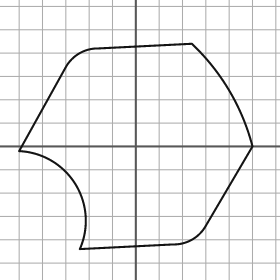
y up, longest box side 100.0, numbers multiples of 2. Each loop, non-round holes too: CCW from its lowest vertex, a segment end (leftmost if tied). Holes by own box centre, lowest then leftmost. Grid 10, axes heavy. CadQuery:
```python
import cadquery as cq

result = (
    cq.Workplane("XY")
    .moveTo(-24.0, -44.0)
    .lineTo(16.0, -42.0)
    .threePointArc((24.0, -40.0), (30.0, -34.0))
    .lineTo(50.0, 0.0)
    .threePointArc((40.0, 24.0), (24.0, 44.0))
    .lineTo(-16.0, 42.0)
    .threePointArc((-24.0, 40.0), (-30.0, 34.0))
    .lineTo(-50.0, -2.0)
    .threePointArc((-26.0, -16.0), (-24.0, -44.0))
    .close()
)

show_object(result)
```